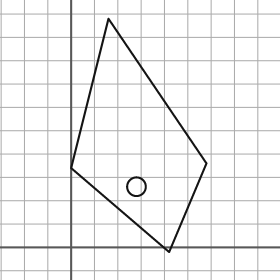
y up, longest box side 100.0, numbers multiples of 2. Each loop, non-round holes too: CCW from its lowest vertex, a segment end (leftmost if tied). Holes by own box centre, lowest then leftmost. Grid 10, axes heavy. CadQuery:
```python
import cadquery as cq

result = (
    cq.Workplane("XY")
    .moveTo(42.0, -2.0)
    .lineTo(58.0, 36.0)
    .lineTo(16.0, 98.0)
    .lineTo(0.0, 34.0)
    .close()
    .moveTo(28.0, 26.0)
    .circle(4.0)
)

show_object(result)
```